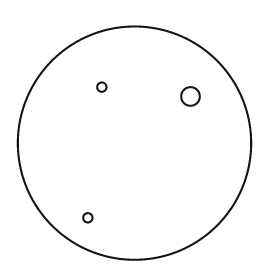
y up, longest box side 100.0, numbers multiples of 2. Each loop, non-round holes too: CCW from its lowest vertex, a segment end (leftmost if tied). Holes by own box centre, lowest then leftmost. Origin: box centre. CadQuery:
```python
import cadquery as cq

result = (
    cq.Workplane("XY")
    .moveTo(0.0, 0.0)
    .circle(50.0)
    .moveTo(-20.0, -32.0)
    .circle(2.0)
    .moveTo(24.0, 20.0)
    .circle(4.0)
    .moveTo(-14.0, 24.0)
    .circle(2.0)
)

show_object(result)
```